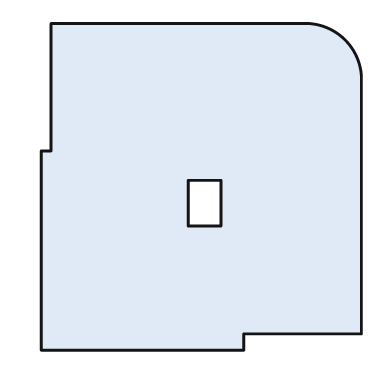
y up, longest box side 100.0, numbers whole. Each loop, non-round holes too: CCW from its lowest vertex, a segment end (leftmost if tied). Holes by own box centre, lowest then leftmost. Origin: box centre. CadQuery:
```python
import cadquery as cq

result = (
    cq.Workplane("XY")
    .moveTo(-49.0, -50.0)
    .lineTo(13.0, -50.0)
    .lineTo(13.0, -45.0)
    .lineTo(49.0, -45.0)
    .lineTo(49.0, 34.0)
    .threePointArc((44.0, 45.0), (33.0, 50.0))
    .lineTo(-46.0, 50.0)
    .lineTo(-46.0, 11.0)
    .lineTo(-49.0, 11.0)
    .close()
    .moveTo(-4.0, -12.0)
    .lineTo(6.0, -12.0)
    .lineTo(6.0, 2.0)
    .lineTo(-4.0, 2.0)
    .close()
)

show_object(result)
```